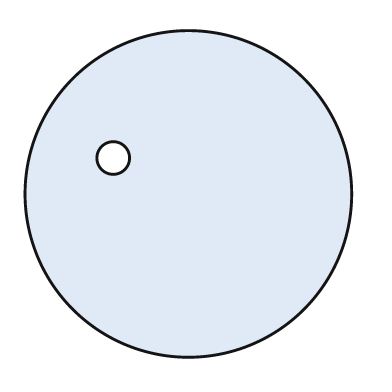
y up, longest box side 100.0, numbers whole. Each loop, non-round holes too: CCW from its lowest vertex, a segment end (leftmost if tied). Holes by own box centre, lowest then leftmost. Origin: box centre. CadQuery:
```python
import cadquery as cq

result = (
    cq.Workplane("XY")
    .moveTo(0.0, 0.0)
    .circle(50.0)
    .moveTo(-23.0, 11.0)
    .circle(5.0)
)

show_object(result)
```